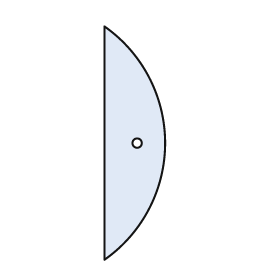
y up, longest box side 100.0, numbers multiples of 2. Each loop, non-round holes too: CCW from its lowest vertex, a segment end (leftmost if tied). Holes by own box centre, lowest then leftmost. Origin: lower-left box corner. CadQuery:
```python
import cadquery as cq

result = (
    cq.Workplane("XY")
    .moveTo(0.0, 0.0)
    .threePointArc((26.0, 50.0), (0.0, 100.0))
    .close()
    .moveTo(14.0, 50.0)
    .circle(2.0)
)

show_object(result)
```